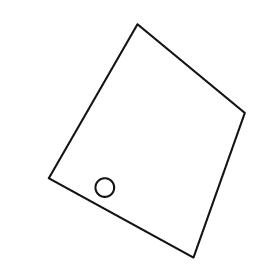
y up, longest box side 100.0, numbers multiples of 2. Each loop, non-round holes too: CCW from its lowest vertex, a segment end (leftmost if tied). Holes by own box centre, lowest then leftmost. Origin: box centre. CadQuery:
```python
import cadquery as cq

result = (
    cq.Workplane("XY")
    .moveTo(20.0, -50.0)
    .lineTo(42.0, 12.0)
    .lineTo(-4.0, 50.0)
    .lineTo(-42.0, -16.0)
    .close()
    .moveTo(-18.0, -20.0)
    .circle(4.0)
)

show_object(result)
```